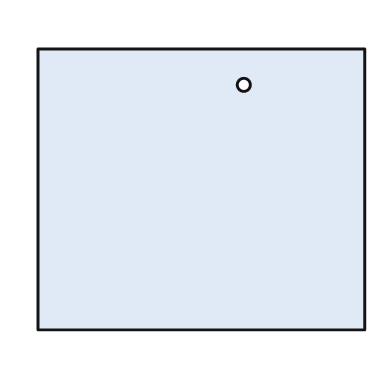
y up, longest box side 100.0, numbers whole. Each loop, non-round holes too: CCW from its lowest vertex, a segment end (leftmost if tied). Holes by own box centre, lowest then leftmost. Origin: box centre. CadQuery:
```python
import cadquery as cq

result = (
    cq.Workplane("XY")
    .moveTo(-50.0, -43.0)
    .lineTo(50.0, -43.0)
    .lineTo(50.0, 43.0)
    .lineTo(-50.0, 43.0)
    .close()
    .moveTo(13.0, 32.0)
    .circle(2.0)
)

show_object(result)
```